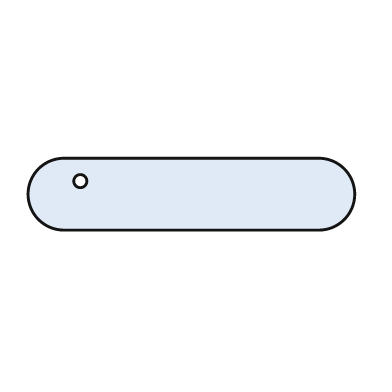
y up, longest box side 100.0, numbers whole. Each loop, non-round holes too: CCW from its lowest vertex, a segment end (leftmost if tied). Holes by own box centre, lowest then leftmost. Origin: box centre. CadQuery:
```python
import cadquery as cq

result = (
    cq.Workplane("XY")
    .moveTo(-39.0, -11.0)
    .lineTo(39.0, -11.0)
    .threePointArc((50.0, 0.0), (39.0, 11.0))
    .lineTo(-39.0, 11.0)
    .threePointArc((-50.0, 0.0), (-39.0, -11.0))
    .close()
    .moveTo(-34.0, 4.0)
    .circle(2.0)
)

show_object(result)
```